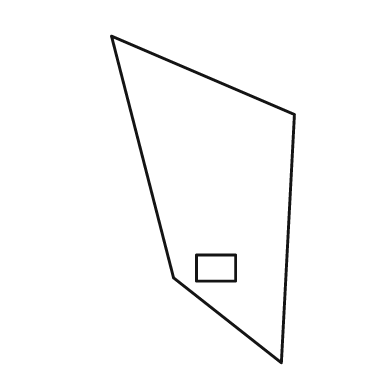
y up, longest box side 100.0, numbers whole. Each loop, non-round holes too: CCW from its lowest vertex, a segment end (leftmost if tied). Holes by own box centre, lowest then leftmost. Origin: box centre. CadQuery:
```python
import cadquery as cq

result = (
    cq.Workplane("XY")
    .moveTo(24.0, -50.0)
    .lineTo(28.0, 26.0)
    .lineTo(-28.0, 50.0)
    .lineTo(-9.0, -24.0)
    .close()
    .moveTo(-2.0, -25.0)
    .lineTo(10.0, -25.0)
    .lineTo(10.0, -17.0)
    .lineTo(-2.0, -17.0)
    .close()
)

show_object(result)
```